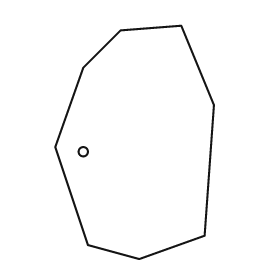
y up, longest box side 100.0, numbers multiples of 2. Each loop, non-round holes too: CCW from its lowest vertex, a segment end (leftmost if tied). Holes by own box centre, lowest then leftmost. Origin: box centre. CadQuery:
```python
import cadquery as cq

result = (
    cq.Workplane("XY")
    .moveTo(2.0, -50.0)
    .lineTo(30.0, -40.0)
    .lineTo(34.0, 16.0)
    .lineTo(20.0, 50.0)
    .lineTo(-6.0, 48.0)
    .lineTo(-22.0, 32.0)
    .lineTo(-34.0, -2.0)
    .lineTo(-20.0, -44.0)
    .close()
    .moveTo(-22.0, -4.0)
    .circle(2.0)
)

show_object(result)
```